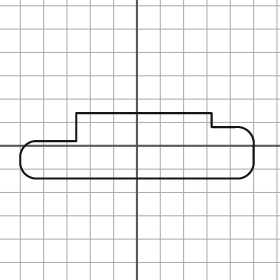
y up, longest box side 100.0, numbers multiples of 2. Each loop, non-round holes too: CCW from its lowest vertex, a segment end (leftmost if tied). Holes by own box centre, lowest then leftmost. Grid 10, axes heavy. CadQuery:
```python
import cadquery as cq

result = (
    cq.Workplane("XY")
    .moveTo(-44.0, -14.0)
    .lineTo(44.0, -14.0)
    .threePointArc((48.0, -12.0), (50.0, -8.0))
    .lineTo(50.0, 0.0)
    .threePointArc((48.0, 6.0), (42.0, 8.0))
    .lineTo(32.0, 8.0)
    .lineTo(32.0, 14.0)
    .lineTo(-26.0, 14.0)
    .lineTo(-26.0, 2.0)
    .lineTo(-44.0, 2.0)
    .threePointArc((-48.0, 0.0), (-50.0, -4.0))
    .lineTo(-50.0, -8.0)
    .threePointArc((-48.0, -12.0), (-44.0, -14.0))
    .close()
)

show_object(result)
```